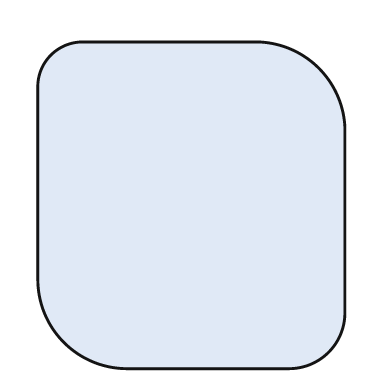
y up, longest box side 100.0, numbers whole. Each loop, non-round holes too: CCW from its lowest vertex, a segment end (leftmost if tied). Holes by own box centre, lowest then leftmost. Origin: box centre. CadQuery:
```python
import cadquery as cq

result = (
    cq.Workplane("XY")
    .moveTo(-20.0, -50.0)
    .lineTo(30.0, -50.0)
    .threePointArc((42.0, -45.0), (47.0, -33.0))
    .lineTo(47.0, 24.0)
    .threePointArc((39.0, 42.0), (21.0, 50.0))
    .lineTo(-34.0, 50.0)
    .threePointArc((-43.0, 46.0), (-47.0, 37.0))
    .lineTo(-47.0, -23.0)
    .threePointArc((-39.0, -42.0), (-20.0, -50.0))
    .close()
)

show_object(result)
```